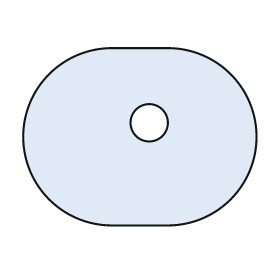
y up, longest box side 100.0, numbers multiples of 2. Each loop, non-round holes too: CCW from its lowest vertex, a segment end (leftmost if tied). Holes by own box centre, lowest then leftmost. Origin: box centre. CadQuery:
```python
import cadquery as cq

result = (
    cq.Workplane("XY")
    .moveTo(-12.0, -38.0)
    .lineTo(12.0, -38.0)
    .threePointArc((50.0, 0.0), (12.0, 38.0))
    .lineTo(-12.0, 38.0)
    .threePointArc((-50.0, 0.0), (-12.0, -38.0))
    .close()
    .moveTo(4.0, 6.0)
    .circle(8.0)
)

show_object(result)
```